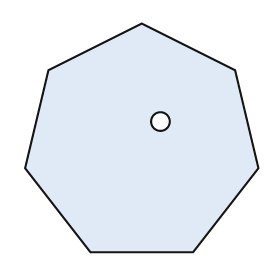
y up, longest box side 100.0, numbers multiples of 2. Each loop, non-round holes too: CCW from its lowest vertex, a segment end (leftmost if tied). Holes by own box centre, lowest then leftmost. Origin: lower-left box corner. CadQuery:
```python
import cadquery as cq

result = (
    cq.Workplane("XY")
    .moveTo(28.0, 0.0)
    .lineTo(72.0, 0.0)
    .lineTo(100.0, 36.0)
    .lineTo(90.0, 78.0)
    .lineTo(50.0, 98.0)
    .lineTo(10.0, 78.0)
    .lineTo(0.0, 36.0)
    .close()
    .moveTo(58.0, 56.0)
    .circle(4.0)
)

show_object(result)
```